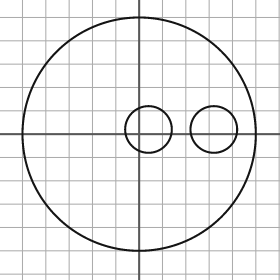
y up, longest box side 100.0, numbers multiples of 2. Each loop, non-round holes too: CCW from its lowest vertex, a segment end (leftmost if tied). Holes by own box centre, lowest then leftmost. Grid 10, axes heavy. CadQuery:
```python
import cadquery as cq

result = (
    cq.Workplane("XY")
    .moveTo(0.0, 0.0)
    .circle(50.0)
    .moveTo(4.0, 2.0)
    .circle(10.0)
    .moveTo(32.0, 2.0)
    .circle(10.0)
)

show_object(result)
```